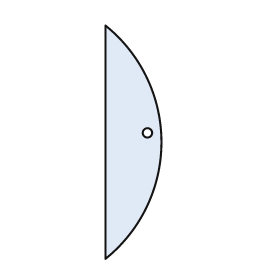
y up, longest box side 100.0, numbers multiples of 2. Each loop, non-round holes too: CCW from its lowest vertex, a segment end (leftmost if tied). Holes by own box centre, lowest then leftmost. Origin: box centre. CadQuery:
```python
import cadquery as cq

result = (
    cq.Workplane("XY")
    .moveTo(-12.0, -50.0)
    .threePointArc((12.0, 0.0), (-12.0, 50.0))
    .close()
    .moveTo(6.0, 4.0)
    .circle(2.0)
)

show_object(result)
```